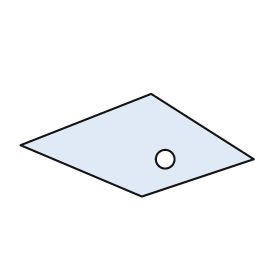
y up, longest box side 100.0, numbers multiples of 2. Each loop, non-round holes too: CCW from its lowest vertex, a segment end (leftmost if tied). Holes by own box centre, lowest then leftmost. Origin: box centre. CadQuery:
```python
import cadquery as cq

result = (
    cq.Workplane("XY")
    .moveTo(2.0, -22.0)
    .lineTo(50.0, -6.0)
    .lineTo(6.0, 22.0)
    .lineTo(-50.0, 0.0)
    .close()
    .moveTo(12.0, -6.0)
    .circle(4.0)
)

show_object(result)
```